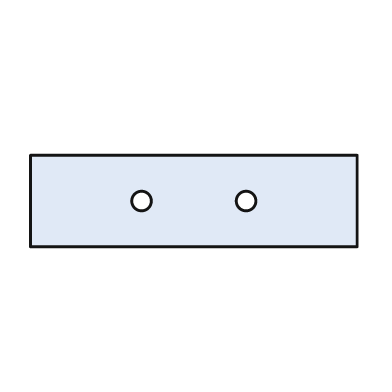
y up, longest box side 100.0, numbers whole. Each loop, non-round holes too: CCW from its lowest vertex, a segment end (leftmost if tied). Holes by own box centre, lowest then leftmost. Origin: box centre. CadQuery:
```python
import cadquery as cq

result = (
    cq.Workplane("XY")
    .moveTo(-50.0, -14.0)
    .lineTo(50.0, -14.0)
    .lineTo(50.0, 14.0)
    .lineTo(-50.0, 14.0)
    .close()
    .moveTo(-16.0, 0.0)
    .circle(3.0)
    .moveTo(16.0, 0.0)
    .circle(3.0)
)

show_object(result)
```